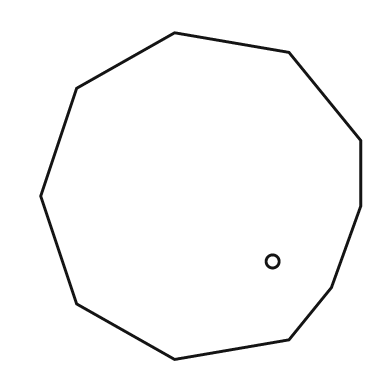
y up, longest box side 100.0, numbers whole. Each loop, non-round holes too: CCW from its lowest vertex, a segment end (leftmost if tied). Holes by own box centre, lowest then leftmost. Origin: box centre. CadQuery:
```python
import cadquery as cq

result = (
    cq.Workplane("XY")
    .moveTo(-8.0, -50.0)
    .lineTo(27.0, -44.0)
    .lineTo(40.0, -28.0)
    .lineTo(49.0, -3.0)
    .lineTo(49.0, 17.0)
    .lineTo(27.0, 44.0)
    .lineTo(-8.0, 50.0)
    .lineTo(-38.0, 33.0)
    .lineTo(-49.0, 0.0)
    .lineTo(-38.0, -33.0)
    .close()
    .moveTo(22.0, -20.0)
    .circle(2.0)
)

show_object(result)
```